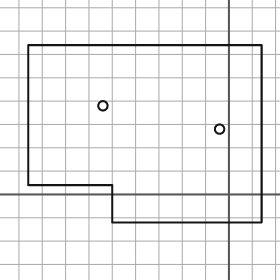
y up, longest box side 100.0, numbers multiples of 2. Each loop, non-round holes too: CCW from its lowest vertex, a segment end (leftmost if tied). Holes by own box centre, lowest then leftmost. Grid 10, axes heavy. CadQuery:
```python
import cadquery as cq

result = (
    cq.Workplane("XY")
    .moveTo(-50.0, -12.0)
    .lineTo(14.0, -12.0)
    .lineTo(14.0, 64.0)
    .lineTo(-86.0, 64.0)
    .lineTo(-86.0, 4.0)
    .lineTo(-50.0, 4.0)
    .close()
    .moveTo(-4.0, 28.0)
    .circle(2.0)
    .moveTo(-54.0, 38.0)
    .circle(2.0)
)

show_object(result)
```